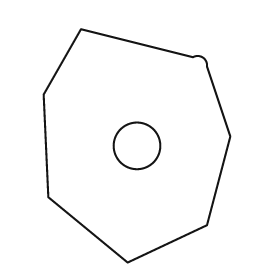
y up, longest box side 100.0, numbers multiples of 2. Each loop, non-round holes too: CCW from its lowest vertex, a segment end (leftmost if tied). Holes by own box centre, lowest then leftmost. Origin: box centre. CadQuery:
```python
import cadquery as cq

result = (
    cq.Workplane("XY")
    .moveTo(-4.0, -50.0)
    .lineTo(30.0, -34.0)
    .lineTo(40.0, 4.0)
    .lineTo(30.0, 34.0)
    .threePointArc((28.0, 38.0), (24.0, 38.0))
    .lineTo(-24.0, 50.0)
    .lineTo(-40.0, 22.0)
    .lineTo(-38.0, -22.0)
    .close()
    .moveTo(0.0, 0.0)
    .circle(10.0)
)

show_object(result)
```